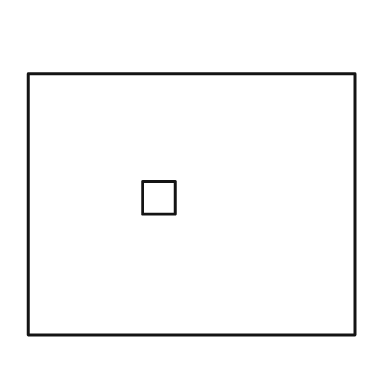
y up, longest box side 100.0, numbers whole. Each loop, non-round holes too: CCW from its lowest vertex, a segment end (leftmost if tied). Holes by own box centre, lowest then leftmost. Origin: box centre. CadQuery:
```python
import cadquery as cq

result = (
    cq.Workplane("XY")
    .moveTo(-50.0, -40.0)
    .lineTo(50.0, -40.0)
    .lineTo(50.0, 40.0)
    .lineTo(-50.0, 40.0)
    .close()
    .moveTo(-15.0, -3.0)
    .lineTo(-5.0, -3.0)
    .lineTo(-5.0, 7.0)
    .lineTo(-15.0, 7.0)
    .close()
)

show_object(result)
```